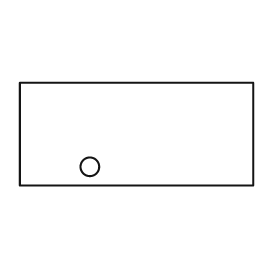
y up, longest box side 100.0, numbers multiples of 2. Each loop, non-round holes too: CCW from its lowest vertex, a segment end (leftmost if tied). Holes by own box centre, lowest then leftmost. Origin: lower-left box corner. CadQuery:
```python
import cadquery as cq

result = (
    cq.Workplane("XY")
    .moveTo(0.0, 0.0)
    .lineTo(100.0, 0.0)
    .lineTo(100.0, 44.0)
    .lineTo(0.0, 44.0)
    .close()
    .moveTo(30.0, 8.0)
    .circle(4.0)
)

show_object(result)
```